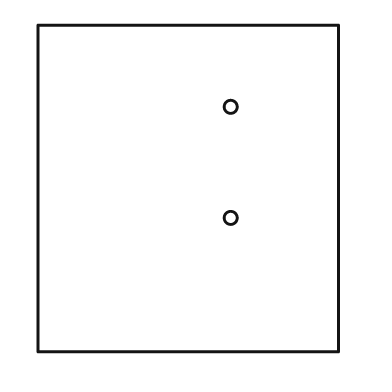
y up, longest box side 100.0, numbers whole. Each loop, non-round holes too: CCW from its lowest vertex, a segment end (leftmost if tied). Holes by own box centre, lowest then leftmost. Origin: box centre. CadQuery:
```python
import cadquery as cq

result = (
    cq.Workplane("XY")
    .moveTo(-46.0, -50.0)
    .lineTo(46.0, -50.0)
    .lineTo(46.0, 50.0)
    .lineTo(-46.0, 50.0)
    .close()
    .moveTo(13.0, -9.0)
    .circle(2.0)
    .moveTo(13.0, 25.0)
    .circle(2.0)
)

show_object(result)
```